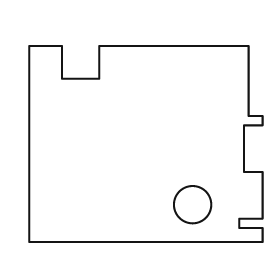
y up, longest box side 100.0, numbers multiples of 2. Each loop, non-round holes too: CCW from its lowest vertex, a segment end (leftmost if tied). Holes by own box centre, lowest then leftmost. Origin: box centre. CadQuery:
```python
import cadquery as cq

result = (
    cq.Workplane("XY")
    .moveTo(-50.0, -42.0)
    .lineTo(50.0, -42.0)
    .lineTo(50.0, -36.0)
    .lineTo(40.0, -36.0)
    .lineTo(40.0, -32.0)
    .lineTo(50.0, -32.0)
    .lineTo(50.0, -12.0)
    .lineTo(42.0, -12.0)
    .lineTo(42.0, 8.0)
    .lineTo(50.0, 8.0)
    .lineTo(50.0, 12.0)
    .lineTo(44.0, 12.0)
    .lineTo(44.0, 42.0)
    .lineTo(-20.0, 42.0)
    .lineTo(-20.0, 28.0)
    .lineTo(-36.0, 28.0)
    .lineTo(-36.0, 42.0)
    .lineTo(-50.0, 42.0)
    .close()
    .moveTo(20.0, -26.0)
    .circle(8.0)
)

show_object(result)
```